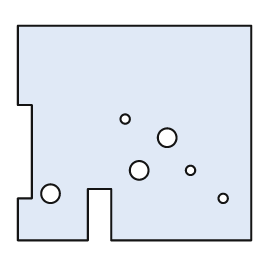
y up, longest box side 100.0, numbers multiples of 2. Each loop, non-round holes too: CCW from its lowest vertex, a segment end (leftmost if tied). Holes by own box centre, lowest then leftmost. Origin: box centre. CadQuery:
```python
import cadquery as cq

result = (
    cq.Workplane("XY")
    .moveTo(-50.0, -46.0)
    .lineTo(-20.0, -46.0)
    .lineTo(-20.0, -24.0)
    .lineTo(-10.0, -24.0)
    .lineTo(-10.0, -46.0)
    .lineTo(50.0, -46.0)
    .lineTo(50.0, 46.0)
    .lineTo(-50.0, 46.0)
    .lineTo(-50.0, 12.0)
    .lineTo(-44.0, 12.0)
    .lineTo(-44.0, -28.0)
    .lineTo(-50.0, -28.0)
    .close()
    .moveTo(38.0, -28.0)
    .circle(2.0)
    .moveTo(-36.0, -26.0)
    .circle(4.0)
    .moveTo(2.0, -16.0)
    .circle(4.0)
    .moveTo(24.0, -16.0)
    .circle(2.0)
    .moveTo(14.0, -2.0)
    .circle(4.0)
    .moveTo(-4.0, 6.0)
    .circle(2.0)
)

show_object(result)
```